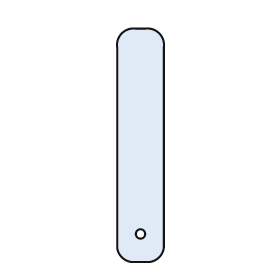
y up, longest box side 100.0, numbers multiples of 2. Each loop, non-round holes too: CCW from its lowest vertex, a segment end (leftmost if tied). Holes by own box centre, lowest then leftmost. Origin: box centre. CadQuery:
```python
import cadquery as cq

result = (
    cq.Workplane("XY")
    .moveTo(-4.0, -50.0)
    .lineTo(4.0, -50.0)
    .threePointArc((8.0, -48.0), (10.0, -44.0))
    .lineTo(10.0, 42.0)
    .threePointArc((8.0, 48.0), (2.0, 50.0))
    .lineTo(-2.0, 50.0)
    .threePointArc((-8.0, 48.0), (-10.0, 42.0))
    .lineTo(-10.0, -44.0)
    .threePointArc((-8.0, -48.0), (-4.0, -50.0))
    .close()
    .moveTo(0.0, -38.0)
    .circle(2.0)
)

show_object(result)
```